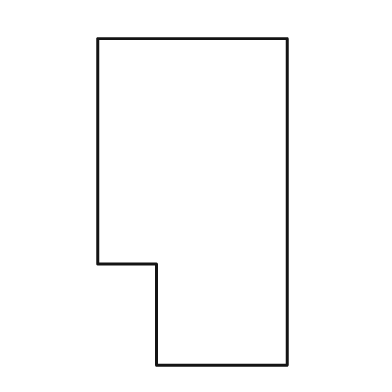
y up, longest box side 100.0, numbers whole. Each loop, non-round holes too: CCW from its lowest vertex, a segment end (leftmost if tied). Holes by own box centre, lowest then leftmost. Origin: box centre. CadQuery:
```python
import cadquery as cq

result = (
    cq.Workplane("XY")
    .moveTo(-11.0, -50.0)
    .lineTo(29.0, -50.0)
    .lineTo(29.0, 50.0)
    .lineTo(-29.0, 50.0)
    .lineTo(-29.0, -19.0)
    .lineTo(-11.0, -19.0)
    .close()
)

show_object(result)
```